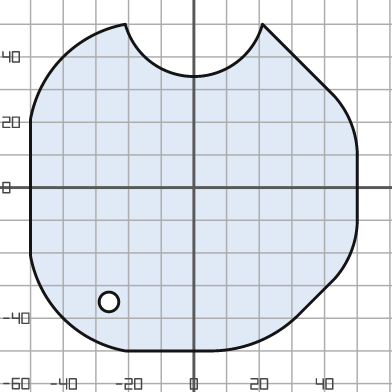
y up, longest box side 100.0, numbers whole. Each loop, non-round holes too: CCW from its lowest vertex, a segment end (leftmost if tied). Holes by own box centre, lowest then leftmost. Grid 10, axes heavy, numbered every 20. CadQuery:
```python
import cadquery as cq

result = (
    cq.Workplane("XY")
    .moveTo(-21.0, -50.0)
    .lineTo(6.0, -50.0)
    .threePointArc((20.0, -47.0), (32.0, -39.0))
    .lineTo(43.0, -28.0)
    .threePointArc((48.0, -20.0), (50.0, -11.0))
    .lineTo(50.0, 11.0)
    .threePointArc((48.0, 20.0), (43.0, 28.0))
    .lineTo(21.0, 50.0)
    .threePointArc((0.0, 34.0), (-21.0, 50.0))
    .threePointArc((-40.0, 40.0), (-50.0, 21.0))
    .lineTo(-50.0, -21.0)
    .threePointArc((-40.0, -40.0), (-21.0, -50.0))
    .close()
    .moveTo(-26.0, -35.0)
    .circle(3.0)
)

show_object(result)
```